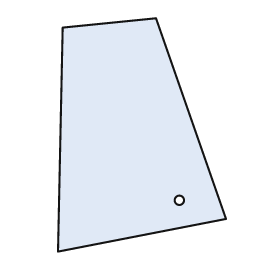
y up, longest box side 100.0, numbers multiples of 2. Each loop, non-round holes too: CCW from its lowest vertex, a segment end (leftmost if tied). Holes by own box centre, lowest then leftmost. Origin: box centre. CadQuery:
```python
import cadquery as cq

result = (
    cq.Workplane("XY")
    .moveTo(-36.0, -50.0)
    .lineTo(36.0, -36.0)
    .lineTo(6.0, 50.0)
    .lineTo(-34.0, 46.0)
    .close()
    .moveTo(16.0, -28.0)
    .circle(2.0)
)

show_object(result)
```